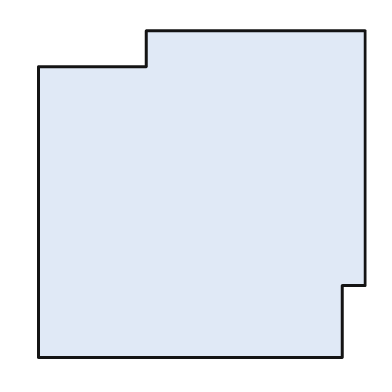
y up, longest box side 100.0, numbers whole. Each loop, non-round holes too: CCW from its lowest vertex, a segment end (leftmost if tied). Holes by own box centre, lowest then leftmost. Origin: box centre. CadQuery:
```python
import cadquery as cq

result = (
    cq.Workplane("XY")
    .moveTo(-50.0, -50.0)
    .lineTo(43.0, -50.0)
    .lineTo(43.0, -28.0)
    .lineTo(50.0, -28.0)
    .lineTo(50.0, 50.0)
    .lineTo(-17.0, 50.0)
    .lineTo(-17.0, 39.0)
    .lineTo(-50.0, 39.0)
    .close()
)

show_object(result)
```